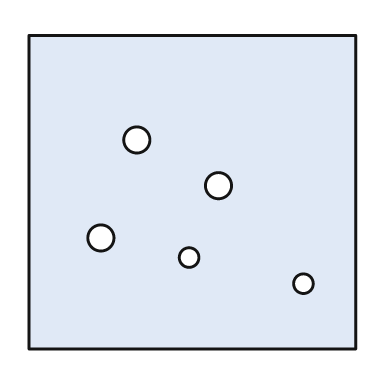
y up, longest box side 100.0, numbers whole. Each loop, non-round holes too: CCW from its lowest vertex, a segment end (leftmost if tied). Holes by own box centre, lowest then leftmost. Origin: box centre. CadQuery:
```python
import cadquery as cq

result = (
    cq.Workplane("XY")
    .moveTo(-50.0, -48.0)
    .lineTo(50.0, -48.0)
    .lineTo(50.0, 48.0)
    .lineTo(-50.0, 48.0)
    .close()
    .moveTo(34.0, -28.0)
    .circle(3.0)
    .moveTo(-1.0, -20.0)
    .circle(3.0)
    .moveTo(-28.0, -14.0)
    .circle(4.0)
    .moveTo(8.0, 2.0)
    .circle(4.0)
    .moveTo(-17.0, 16.0)
    .circle(4.0)
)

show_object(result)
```